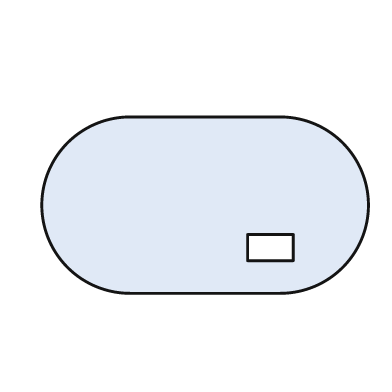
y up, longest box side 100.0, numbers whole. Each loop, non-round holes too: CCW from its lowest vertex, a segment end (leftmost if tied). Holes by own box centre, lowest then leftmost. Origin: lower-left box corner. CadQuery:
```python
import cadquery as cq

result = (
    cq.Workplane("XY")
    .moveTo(27.0, 0.0)
    .lineTo(73.0, 0.0)
    .threePointArc((100.0, 27.0), (73.0, 54.0))
    .lineTo(27.0, 54.0)
    .threePointArc((0.0, 27.0), (27.0, 0.0))
    .close()
    .moveTo(63.0, 10.0)
    .lineTo(77.0, 10.0)
    .lineTo(77.0, 18.0)
    .lineTo(63.0, 18.0)
    .close()
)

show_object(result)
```